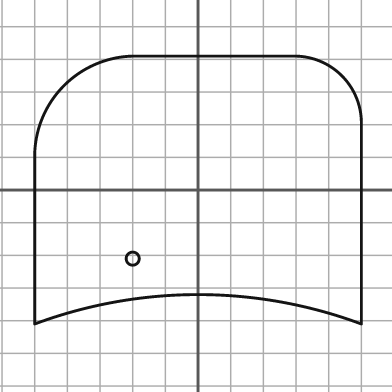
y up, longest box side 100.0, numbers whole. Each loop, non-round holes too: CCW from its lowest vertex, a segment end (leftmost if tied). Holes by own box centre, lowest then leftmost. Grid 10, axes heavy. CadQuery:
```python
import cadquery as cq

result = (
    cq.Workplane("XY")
    .moveTo(-50.0, -41.0)
    .threePointArc((0.0, -32.0), (50.0, -41.0))
    .lineTo(50.0, 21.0)
    .threePointArc((44.0, 35.0), (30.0, 41.0))
    .lineTo(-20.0, 41.0)
    .threePointArc((-41.0, 32.0), (-50.0, 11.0))
    .close()
    .moveTo(-20.0, -21.0)
    .circle(2.0)
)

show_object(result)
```